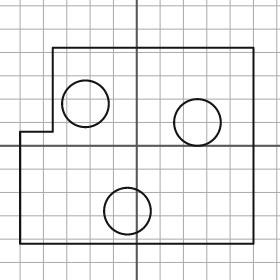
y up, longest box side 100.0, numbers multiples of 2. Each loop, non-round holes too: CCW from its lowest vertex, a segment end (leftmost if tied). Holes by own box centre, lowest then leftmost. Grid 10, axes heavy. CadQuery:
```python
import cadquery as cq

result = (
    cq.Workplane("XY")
    .moveTo(-50.0, -42.0)
    .lineTo(50.0, -42.0)
    .lineTo(50.0, 42.0)
    .lineTo(-36.0, 42.0)
    .lineTo(-36.0, 6.0)
    .lineTo(-50.0, 6.0)
    .close()
    .moveTo(-4.0, -28.0)
    .circle(10.0)
    .moveTo(26.0, 10.0)
    .circle(10.0)
    .moveTo(-22.0, 18.0)
    .circle(10.0)
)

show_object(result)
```